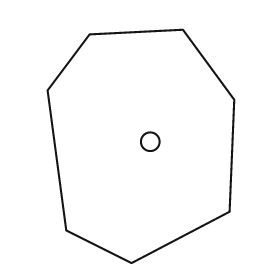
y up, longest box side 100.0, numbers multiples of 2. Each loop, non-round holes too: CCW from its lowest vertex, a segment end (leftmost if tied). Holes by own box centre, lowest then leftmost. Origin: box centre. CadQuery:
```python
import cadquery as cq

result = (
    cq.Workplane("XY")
    .moveTo(-4.0, -50.0)
    .lineTo(38.0, -28.0)
    .lineTo(40.0, 20.0)
    .lineTo(18.0, 50.0)
    .lineTo(-22.0, 48.0)
    .lineTo(-40.0, 24.0)
    .lineTo(-32.0, -36.0)
    .close()
    .moveTo(4.0, 2.0)
    .circle(4.0)
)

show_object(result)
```